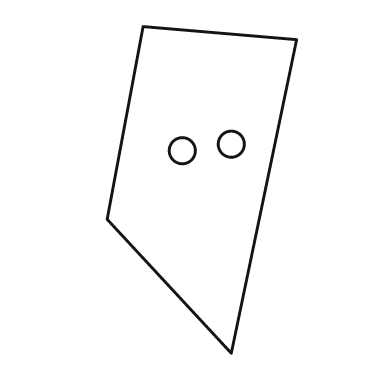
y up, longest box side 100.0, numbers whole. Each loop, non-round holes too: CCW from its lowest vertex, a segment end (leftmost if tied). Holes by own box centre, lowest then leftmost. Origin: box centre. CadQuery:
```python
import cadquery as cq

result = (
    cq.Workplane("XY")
    .moveTo(9.0, -50.0)
    .lineTo(29.0, 46.0)
    .lineTo(-18.0, 50.0)
    .lineTo(-29.0, -9.0)
    .close()
    .moveTo(-6.0, 12.0)
    .circle(4.0)
    .moveTo(9.0, 14.0)
    .circle(4.0)
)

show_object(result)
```